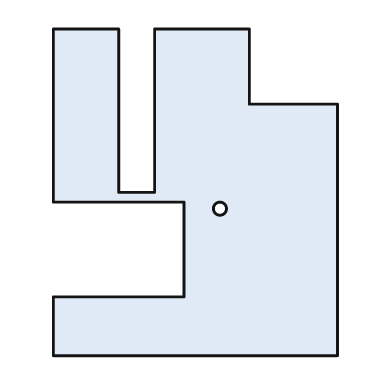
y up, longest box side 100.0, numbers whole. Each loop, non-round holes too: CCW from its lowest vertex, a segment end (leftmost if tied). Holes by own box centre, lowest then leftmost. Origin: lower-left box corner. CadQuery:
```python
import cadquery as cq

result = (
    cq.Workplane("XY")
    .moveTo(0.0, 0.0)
    .lineTo(87.0, 0.0)
    .lineTo(87.0, 77.0)
    .lineTo(60.0, 77.0)
    .lineTo(60.0, 100.0)
    .lineTo(31.0, 100.0)
    .lineTo(31.0, 50.0)
    .lineTo(20.0, 50.0)
    .lineTo(20.0, 100.0)
    .lineTo(0.0, 100.0)
    .lineTo(0.0, 47.0)
    .lineTo(40.0, 47.0)
    .lineTo(40.0, 18.0)
    .lineTo(0.0, 18.0)
    .close()
    .moveTo(51.0, 45.0)
    .circle(2.0)
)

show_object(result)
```